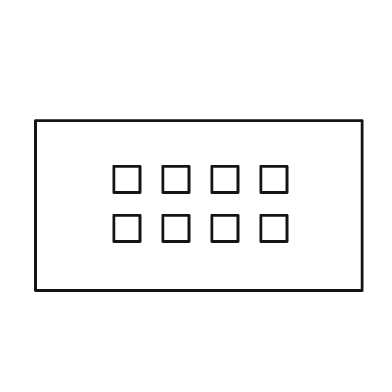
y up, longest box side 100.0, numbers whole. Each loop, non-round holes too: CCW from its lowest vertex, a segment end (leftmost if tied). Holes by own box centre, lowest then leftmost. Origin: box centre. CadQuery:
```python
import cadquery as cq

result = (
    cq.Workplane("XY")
    .moveTo(-50.0, -26.0)
    .lineTo(50.0, -26.0)
    .lineTo(50.0, 26.0)
    .lineTo(-50.0, 26.0)
    .close()
    .moveTo(-26.0, -11.0)
    .lineTo(-18.0, -11.0)
    .lineTo(-18.0, -3.0)
    .lineTo(-26.0, -3.0)
    .close()
    .moveTo(-11.0, -11.0)
    .lineTo(-3.0, -11.0)
    .lineTo(-3.0, -3.0)
    .lineTo(-11.0, -3.0)
    .close()
    .moveTo(4.0, -11.0)
    .lineTo(12.0, -11.0)
    .lineTo(12.0, -3.0)
    .lineTo(4.0, -3.0)
    .close()
    .moveTo(19.0, -11.0)
    .lineTo(27.0, -11.0)
    .lineTo(27.0, -3.0)
    .lineTo(19.0, -3.0)
    .close()
    .moveTo(-26.0, 4.0)
    .lineTo(-18.0, 4.0)
    .lineTo(-18.0, 12.0)
    .lineTo(-26.0, 12.0)
    .close()
    .moveTo(-11.0, 4.0)
    .lineTo(-3.0, 4.0)
    .lineTo(-3.0, 12.0)
    .lineTo(-11.0, 12.0)
    .close()
    .moveTo(4.0, 4.0)
    .lineTo(12.0, 4.0)
    .lineTo(12.0, 12.0)
    .lineTo(4.0, 12.0)
    .close()
    .moveTo(19.0, 4.0)
    .lineTo(27.0, 4.0)
    .lineTo(27.0, 12.0)
    .lineTo(19.0, 12.0)
    .close()
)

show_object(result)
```